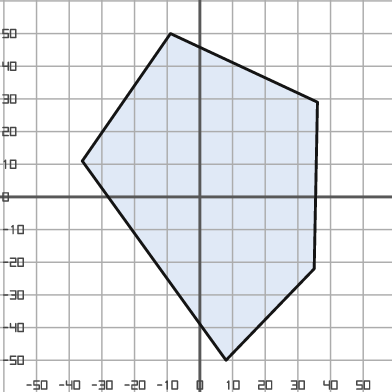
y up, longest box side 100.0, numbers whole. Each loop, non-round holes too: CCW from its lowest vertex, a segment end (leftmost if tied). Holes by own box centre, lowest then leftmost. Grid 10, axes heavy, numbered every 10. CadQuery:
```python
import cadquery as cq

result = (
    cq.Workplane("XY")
    .moveTo(8.0, -50.0)
    .lineTo(35.0, -22.0)
    .lineTo(36.0, 29.0)
    .lineTo(-9.0, 50.0)
    .lineTo(-36.0, 11.0)
    .close()
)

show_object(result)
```